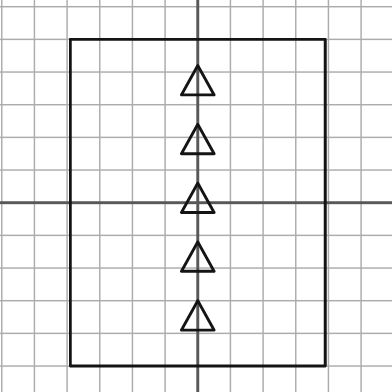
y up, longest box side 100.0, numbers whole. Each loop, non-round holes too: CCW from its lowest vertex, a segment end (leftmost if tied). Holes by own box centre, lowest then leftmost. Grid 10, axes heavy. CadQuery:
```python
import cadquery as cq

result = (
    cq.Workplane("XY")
    .moveTo(-39.0, -50.0)
    .lineTo(39.0, -50.0)
    .lineTo(39.0, 50.0)
    .lineTo(-39.0, 50.0)
    .close()
    .moveTo(-5.0, -39.0)
    .lineTo(5.0, -39.0)
    .lineTo(0.0, -30.0)
    .close()
    .moveTo(-5.0, -21.0)
    .lineTo(5.0, -21.0)
    .lineTo(0.0, -12.0)
    .close()
    .moveTo(-5.0, -3.0)
    .lineTo(5.0, -3.0)
    .lineTo(0.0, 6.0)
    .close()
    .moveTo(-5.0, 15.0)
    .lineTo(5.0, 15.0)
    .lineTo(0.0, 24.0)
    .close()
    .moveTo(-5.0, 33.0)
    .lineTo(5.0, 33.0)
    .lineTo(0.0, 42.0)
    .close()
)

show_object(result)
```